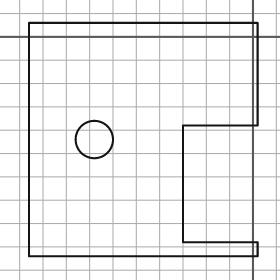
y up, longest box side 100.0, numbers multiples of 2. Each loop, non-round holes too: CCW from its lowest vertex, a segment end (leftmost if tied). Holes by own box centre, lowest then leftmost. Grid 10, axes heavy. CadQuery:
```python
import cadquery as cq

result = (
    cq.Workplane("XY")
    .moveTo(-96.0, -94.0)
    .lineTo(2.0, -94.0)
    .lineTo(2.0, -88.0)
    .lineTo(-30.0, -88.0)
    .lineTo(-30.0, -38.0)
    .lineTo(2.0, -38.0)
    .lineTo(2.0, 6.0)
    .lineTo(-96.0, 6.0)
    .close()
    .moveTo(-68.0, -44.0)
    .circle(8.0)
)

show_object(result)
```